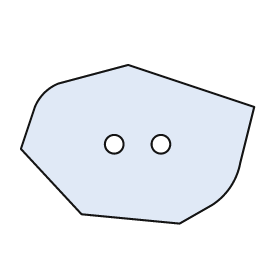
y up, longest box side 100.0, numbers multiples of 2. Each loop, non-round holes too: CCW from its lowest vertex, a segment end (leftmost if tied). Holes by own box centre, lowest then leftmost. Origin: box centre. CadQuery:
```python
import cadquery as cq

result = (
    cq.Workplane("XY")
    .moveTo(18.0, -34.0)
    .lineTo(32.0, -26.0)
    .threePointArc((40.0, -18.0), (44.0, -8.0))
    .lineTo(50.0, 16.0)
    .lineTo(-4.0, 34.0)
    .lineTo(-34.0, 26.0)
    .threePointArc((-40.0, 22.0), (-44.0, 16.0))
    .lineTo(-50.0, -2.0)
    .lineTo(-24.0, -30.0)
    .close()
    .moveTo(-10.0, 0.0)
    .circle(4.0)
    .moveTo(10.0, 0.0)
    .circle(4.0)
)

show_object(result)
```